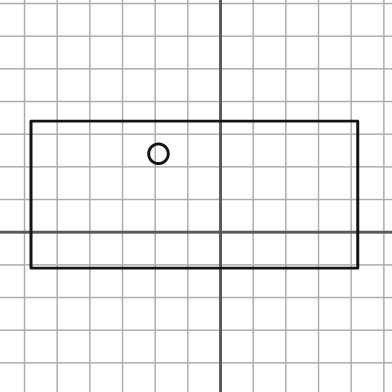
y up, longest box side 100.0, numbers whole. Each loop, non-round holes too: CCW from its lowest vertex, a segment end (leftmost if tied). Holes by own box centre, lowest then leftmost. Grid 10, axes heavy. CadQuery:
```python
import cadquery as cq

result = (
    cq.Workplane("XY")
    .moveTo(-58.0, -11.0)
    .lineTo(42.0, -11.0)
    .lineTo(42.0, 34.0)
    .lineTo(-58.0, 34.0)
    .close()
    .moveTo(-19.0, 24.0)
    .circle(3.0)
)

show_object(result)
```